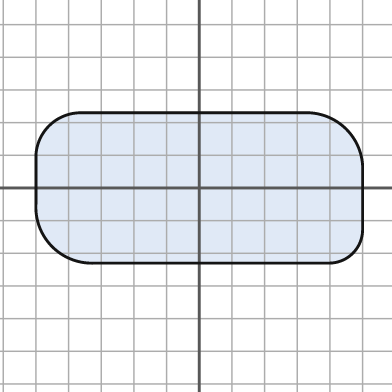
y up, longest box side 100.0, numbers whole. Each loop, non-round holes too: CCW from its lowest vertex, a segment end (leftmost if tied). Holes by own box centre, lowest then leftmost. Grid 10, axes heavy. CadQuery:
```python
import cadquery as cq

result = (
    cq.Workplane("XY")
    .moveTo(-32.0, -23.0)
    .lineTo(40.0, -23.0)
    .threePointArc((47.0, -20.0), (50.0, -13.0))
    .lineTo(50.0, 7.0)
    .threePointArc((45.0, 18.0), (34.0, 23.0))
    .lineTo(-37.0, 23.0)
    .threePointArc((-46.0, 19.0), (-50.0, 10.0))
    .lineTo(-50.0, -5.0)
    .threePointArc((-45.0, -18.0), (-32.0, -23.0))
    .close()
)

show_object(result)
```